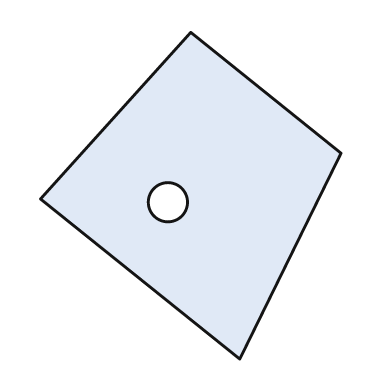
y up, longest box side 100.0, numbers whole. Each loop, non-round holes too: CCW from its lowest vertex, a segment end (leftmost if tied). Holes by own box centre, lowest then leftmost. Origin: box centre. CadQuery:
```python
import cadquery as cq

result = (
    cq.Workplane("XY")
    .moveTo(15.0, -50.0)
    .lineTo(46.0, 13.0)
    .lineTo(0.0, 50.0)
    .lineTo(-46.0, -1.0)
    .close()
    .moveTo(-7.0, -2.0)
    .circle(6.0)
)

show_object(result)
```